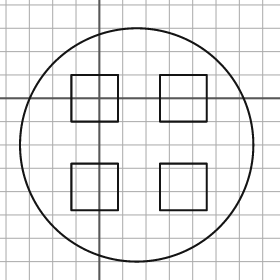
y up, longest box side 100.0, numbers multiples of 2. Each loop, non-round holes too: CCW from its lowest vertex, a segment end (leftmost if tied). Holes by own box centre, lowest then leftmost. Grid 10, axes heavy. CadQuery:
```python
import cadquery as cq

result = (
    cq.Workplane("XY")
    .moveTo(16.0, -20.0)
    .circle(50.0)
    .moveTo(-12.0, -48.0)
    .lineTo(8.0, -48.0)
    .lineTo(8.0, -28.0)
    .lineTo(-12.0, -28.0)
    .close()
    .moveTo(26.0, -48.0)
    .lineTo(46.0, -48.0)
    .lineTo(46.0, -28.0)
    .lineTo(26.0, -28.0)
    .close()
    .moveTo(-12.0, -10.0)
    .lineTo(8.0, -10.0)
    .lineTo(8.0, 10.0)
    .lineTo(-12.0, 10.0)
    .close()
    .moveTo(26.0, -10.0)
    .lineTo(46.0, -10.0)
    .lineTo(46.0, 10.0)
    .lineTo(26.0, 10.0)
    .close()
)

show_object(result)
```